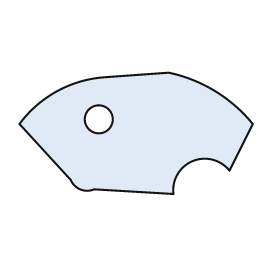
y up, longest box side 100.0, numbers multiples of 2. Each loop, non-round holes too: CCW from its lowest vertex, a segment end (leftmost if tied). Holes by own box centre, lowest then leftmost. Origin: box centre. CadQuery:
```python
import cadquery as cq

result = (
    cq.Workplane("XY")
    .moveTo(16.0, -26.0)
    .threePointArc((24.0, -12.0), (40.0, -16.0))
    .lineTo(50.0, 4.0)
    .threePointArc((34.0, 18.0), (14.0, 26.0))
    .lineTo(-14.0, 24.0)
    .threePointArc((-34.0, 18.0), (-50.0, 4.0))
    .lineTo(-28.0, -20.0)
    .threePointArc((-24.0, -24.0), (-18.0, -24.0))
    .close()
    .moveTo(-16.0, 6.0)
    .circle(6.0)
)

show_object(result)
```